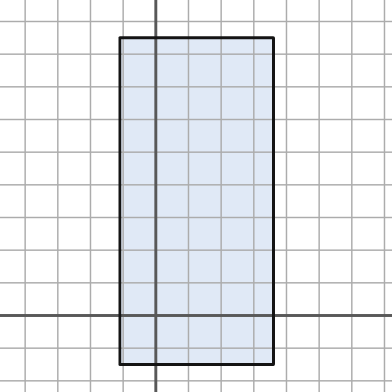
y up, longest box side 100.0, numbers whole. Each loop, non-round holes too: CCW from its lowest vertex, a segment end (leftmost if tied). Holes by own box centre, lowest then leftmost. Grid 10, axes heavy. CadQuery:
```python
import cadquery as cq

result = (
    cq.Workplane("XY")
    .moveTo(-11.0, -15.0)
    .lineTo(36.0, -15.0)
    .lineTo(36.0, 85.0)
    .lineTo(-11.0, 85.0)
    .close()
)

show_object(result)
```